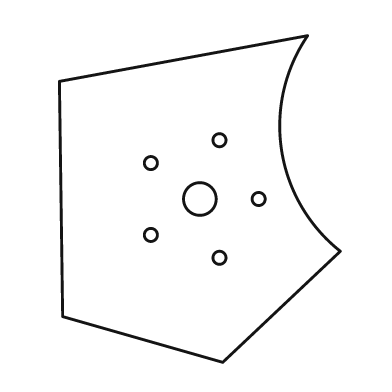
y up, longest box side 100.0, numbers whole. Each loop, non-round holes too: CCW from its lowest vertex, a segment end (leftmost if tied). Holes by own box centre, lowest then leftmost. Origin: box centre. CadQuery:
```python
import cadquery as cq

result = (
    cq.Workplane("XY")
    .moveTo(7.0, -50.0)
    .lineTo(43.0, -16.0)
    .threePointArc((25.0, 15.0), (33.0, 50.0))
    .lineTo(-43.0, 36.0)
    .lineTo(-42.0, -36.0)
    .close()
    .moveTo(6.0, -18.0)
    .circle(2.0)
    .moveTo(-15.0, -11.0)
    .circle(2.0)
    .moveTo(0.0, 0.0)
    .circle(5.0)
    .moveTo(18.0, 0.0)
    .circle(2.0)
    .moveTo(-15.0, 11.0)
    .circle(2.0)
    .moveTo(6.0, 18.0)
    .circle(2.0)
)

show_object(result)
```